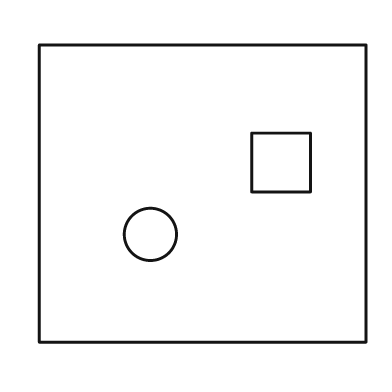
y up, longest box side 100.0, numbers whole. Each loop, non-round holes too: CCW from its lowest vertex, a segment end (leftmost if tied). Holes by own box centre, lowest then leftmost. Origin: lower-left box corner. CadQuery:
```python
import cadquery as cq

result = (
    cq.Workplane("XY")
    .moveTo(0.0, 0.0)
    .lineTo(100.0, 0.0)
    .lineTo(100.0, 91.0)
    .lineTo(0.0, 91.0)
    .close()
    .moveTo(34.0, 33.0)
    .circle(8.0)
    .moveTo(65.0, 46.0)
    .lineTo(83.0, 46.0)
    .lineTo(83.0, 64.0)
    .lineTo(65.0, 64.0)
    .close()
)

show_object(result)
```